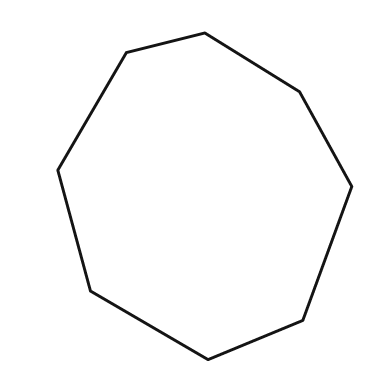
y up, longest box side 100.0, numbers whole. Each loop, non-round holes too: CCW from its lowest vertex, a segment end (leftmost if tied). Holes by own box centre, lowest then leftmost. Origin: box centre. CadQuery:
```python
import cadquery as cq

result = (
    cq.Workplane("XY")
    .moveTo(1.0, -50.0)
    .lineTo(30.0, -38.0)
    .lineTo(45.0, 3.0)
    .lineTo(29.0, 32.0)
    .lineTo(0.0, 50.0)
    .lineTo(-24.0, 44.0)
    .lineTo(-45.0, 8.0)
    .lineTo(-35.0, -29.0)
    .close()
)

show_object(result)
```